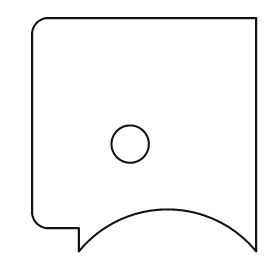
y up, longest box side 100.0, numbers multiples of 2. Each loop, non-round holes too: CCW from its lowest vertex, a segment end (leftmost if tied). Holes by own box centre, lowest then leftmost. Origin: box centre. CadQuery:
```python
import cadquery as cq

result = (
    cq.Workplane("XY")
    .moveTo(-28.0, -50.0)
    .threePointArc((10.0, -32.0), (48.0, -50.0))
    .lineTo(48.0, 50.0)
    .lineTo(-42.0, 50.0)
    .threePointArc((-46.0, 48.0), (-48.0, 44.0))
    .lineTo(-48.0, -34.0)
    .threePointArc((-46.0, -38.0), (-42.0, -40.0))
    .lineTo(-28.0, -40.0)
    .close()
    .moveTo(-6.0, -4.0)
    .circle(8.0)
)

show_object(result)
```